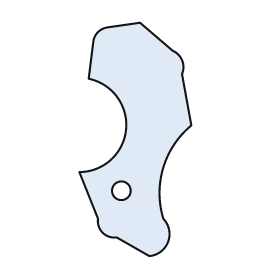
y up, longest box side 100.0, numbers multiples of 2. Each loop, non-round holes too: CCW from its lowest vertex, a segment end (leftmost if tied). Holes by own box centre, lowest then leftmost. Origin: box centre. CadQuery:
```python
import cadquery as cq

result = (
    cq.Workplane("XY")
    .moveTo(6.0, -50.0)
    .threePointArc((14.0, -44.0), (12.0, -34.0))
    .threePointArc((12.0, -12.0), (24.0, 6.0))
    .lineTo(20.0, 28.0)
    .threePointArc((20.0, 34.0), (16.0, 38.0))
    .lineTo(2.0, 50.0)
    .lineTo(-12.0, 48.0)
    .threePointArc((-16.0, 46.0), (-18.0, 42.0))
    .lineTo(-20.0, 26.0)
    .threePointArc((-4.0, 4.0), (-24.0, -14.0))
    .lineTo(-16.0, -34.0)
    .threePointArc((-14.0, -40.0), (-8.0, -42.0))
    .close()
    .moveTo(-6.0, -22.0)
    .circle(4.0)
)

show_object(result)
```